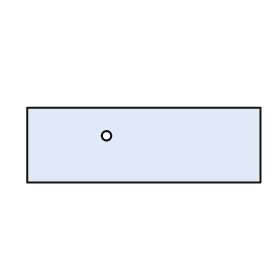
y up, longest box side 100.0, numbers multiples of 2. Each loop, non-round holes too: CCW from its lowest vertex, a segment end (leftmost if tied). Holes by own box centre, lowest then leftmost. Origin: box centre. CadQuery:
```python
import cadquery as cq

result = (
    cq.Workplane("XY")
    .moveTo(-50.0, -16.0)
    .lineTo(50.0, -16.0)
    .lineTo(50.0, 16.0)
    .lineTo(-50.0, 16.0)
    .close()
    .moveTo(-16.0, 4.0)
    .circle(2.0)
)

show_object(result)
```